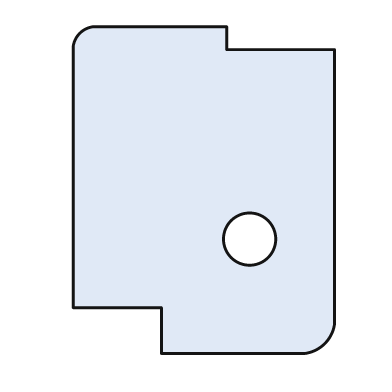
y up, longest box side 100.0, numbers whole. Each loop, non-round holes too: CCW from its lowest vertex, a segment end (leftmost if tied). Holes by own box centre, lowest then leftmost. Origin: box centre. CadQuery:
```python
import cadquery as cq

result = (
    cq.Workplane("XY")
    .moveTo(-13.0, -50.0)
    .lineTo(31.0, -50.0)
    .threePointArc((37.0, -47.0), (40.0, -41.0))
    .lineTo(40.0, 43.0)
    .lineTo(7.0, 43.0)
    .lineTo(7.0, 50.0)
    .lineTo(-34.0, 50.0)
    .threePointArc((-38.0, 48.0), (-40.0, 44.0))
    .lineTo(-40.0, -36.0)
    .lineTo(-13.0, -36.0)
    .close()
    .moveTo(14.0, -15.0)
    .circle(8.0)
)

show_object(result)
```